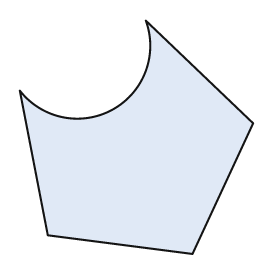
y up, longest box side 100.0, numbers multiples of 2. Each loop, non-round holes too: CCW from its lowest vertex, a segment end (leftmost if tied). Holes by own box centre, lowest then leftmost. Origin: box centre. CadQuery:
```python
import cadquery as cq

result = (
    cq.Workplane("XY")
    .moveTo(24.0, -50.0)
    .lineTo(50.0, 6.0)
    .lineTo(4.0, 50.0)
    .threePointArc((-10.0, 12.0), (-50.0, 20.0))
    .lineTo(-38.0, -42.0)
    .close()
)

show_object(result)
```